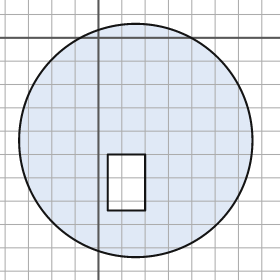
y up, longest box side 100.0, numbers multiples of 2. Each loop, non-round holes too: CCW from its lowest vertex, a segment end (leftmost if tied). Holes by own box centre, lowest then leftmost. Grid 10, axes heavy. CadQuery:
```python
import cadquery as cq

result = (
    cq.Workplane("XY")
    .moveTo(16.0, -44.0)
    .circle(50.0)
    .moveTo(4.0, -74.0)
    .lineTo(20.0, -74.0)
    .lineTo(20.0, -50.0)
    .lineTo(4.0, -50.0)
    .close()
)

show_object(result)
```